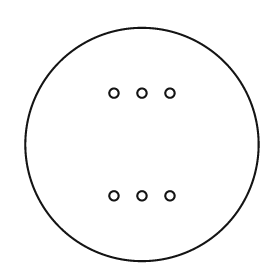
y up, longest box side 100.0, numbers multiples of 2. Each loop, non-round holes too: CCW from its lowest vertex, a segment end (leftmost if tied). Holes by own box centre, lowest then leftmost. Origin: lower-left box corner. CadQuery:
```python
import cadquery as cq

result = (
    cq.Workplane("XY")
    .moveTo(50.0, 50.0)
    .circle(50.0)
    .moveTo(38.0, 28.0)
    .circle(2.0)
    .moveTo(50.0, 28.0)
    .circle(2.0)
    .moveTo(62.0, 28.0)
    .circle(2.0)
    .moveTo(38.0, 72.0)
    .circle(2.0)
    .moveTo(50.0, 72.0)
    .circle(2.0)
    .moveTo(62.0, 72.0)
    .circle(2.0)
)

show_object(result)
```